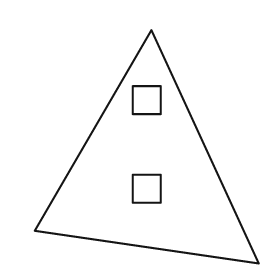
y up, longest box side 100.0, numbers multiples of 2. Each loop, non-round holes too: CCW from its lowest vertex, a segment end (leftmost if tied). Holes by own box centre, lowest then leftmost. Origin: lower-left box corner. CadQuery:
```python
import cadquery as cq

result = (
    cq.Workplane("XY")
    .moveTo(96.0, 0.0)
    .lineTo(50.0, 100.0)
    .lineTo(0.0, 14.0)
    .close()
    .moveTo(42.0, 26.0)
    .lineTo(54.0, 26.0)
    .lineTo(54.0, 38.0)
    .lineTo(42.0, 38.0)
    .close()
    .moveTo(42.0, 64.0)
    .lineTo(54.0, 64.0)
    .lineTo(54.0, 76.0)
    .lineTo(42.0, 76.0)
    .close()
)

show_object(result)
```